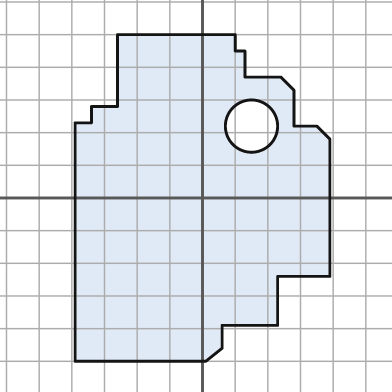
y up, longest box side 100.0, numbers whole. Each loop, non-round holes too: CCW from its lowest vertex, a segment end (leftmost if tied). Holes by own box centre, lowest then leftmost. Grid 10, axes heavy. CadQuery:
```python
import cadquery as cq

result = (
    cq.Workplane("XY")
    .moveTo(-39.0, -50.0)
    .lineTo(1.0, -50.0)
    .lineTo(6.0, -46.0)
    .lineTo(6.0, -39.0)
    .lineTo(23.0, -39.0)
    .lineTo(23.0, -24.0)
    .lineTo(39.0, -24.0)
    .lineTo(39.0, 18.0)
    .lineTo(35.0, 22.0)
    .lineTo(28.0, 22.0)
    .lineTo(28.0, 33.0)
    .lineTo(24.0, 37.0)
    .lineTo(13.0, 37.0)
    .lineTo(13.0, 45.0)
    .lineTo(10.0, 45.0)
    .lineTo(10.0, 50.0)
    .lineTo(-26.0, 50.0)
    .lineTo(-26.0, 28.0)
    .lineTo(-34.0, 28.0)
    .lineTo(-34.0, 23.0)
    .lineTo(-39.0, 23.0)
    .close()
    .moveTo(15.0, 22.0)
    .circle(8.0)
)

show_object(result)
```